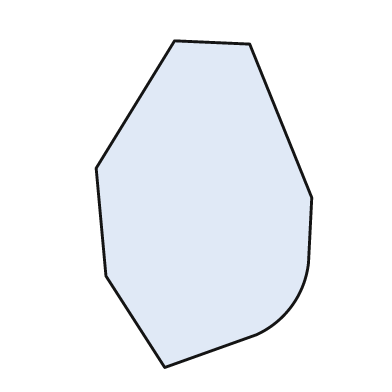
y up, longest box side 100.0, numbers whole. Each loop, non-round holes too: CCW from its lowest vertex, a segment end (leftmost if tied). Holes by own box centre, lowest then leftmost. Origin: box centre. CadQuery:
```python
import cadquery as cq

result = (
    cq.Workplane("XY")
    .moveTo(-12.0, -50.0)
    .lineTo(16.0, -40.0)
    .threePointArc((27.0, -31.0), (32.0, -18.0))
    .lineTo(33.0, 2.0)
    .lineTo(14.0, 49.0)
    .lineTo(-9.0, 50.0)
    .lineTo(-33.0, 11.0)
    .lineTo(-30.0, -22.0)
    .close()
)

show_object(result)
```